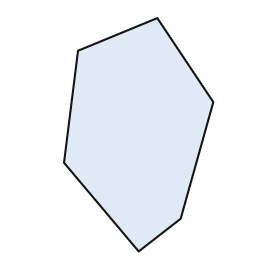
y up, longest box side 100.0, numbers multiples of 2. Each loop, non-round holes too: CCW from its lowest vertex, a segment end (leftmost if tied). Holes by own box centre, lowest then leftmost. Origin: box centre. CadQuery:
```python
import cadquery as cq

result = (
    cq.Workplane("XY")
    .moveTo(0.0, -50.0)
    .lineTo(18.0, -36.0)
    .lineTo(32.0, 14.0)
    .lineTo(8.0, 50.0)
    .lineTo(-26.0, 36.0)
    .lineTo(-32.0, -12.0)
    .close()
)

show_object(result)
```